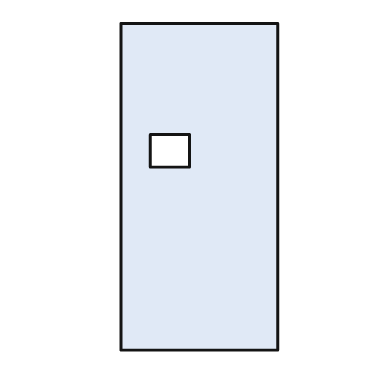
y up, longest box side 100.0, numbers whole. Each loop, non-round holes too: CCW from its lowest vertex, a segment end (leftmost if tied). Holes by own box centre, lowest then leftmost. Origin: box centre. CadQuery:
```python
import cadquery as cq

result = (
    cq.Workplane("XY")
    .moveTo(-24.0, -50.0)
    .lineTo(24.0, -50.0)
    .lineTo(24.0, 50.0)
    .lineTo(-24.0, 50.0)
    .close()
    .moveTo(-15.0, 6.0)
    .lineTo(-3.0, 6.0)
    .lineTo(-3.0, 16.0)
    .lineTo(-15.0, 16.0)
    .close()
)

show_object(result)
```